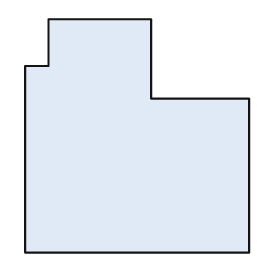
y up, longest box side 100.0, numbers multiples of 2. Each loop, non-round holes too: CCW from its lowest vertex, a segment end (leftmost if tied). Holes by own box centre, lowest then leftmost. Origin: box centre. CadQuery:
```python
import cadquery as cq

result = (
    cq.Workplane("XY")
    .moveTo(-48.0, -50.0)
    .lineTo(48.0, -50.0)
    .lineTo(48.0, 16.0)
    .lineTo(6.0, 16.0)
    .lineTo(6.0, 50.0)
    .lineTo(-38.0, 50.0)
    .lineTo(-38.0, 30.0)
    .lineTo(-48.0, 30.0)
    .close()
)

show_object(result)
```